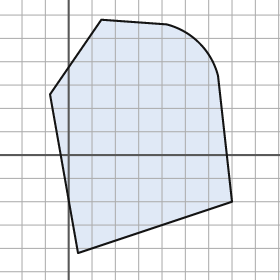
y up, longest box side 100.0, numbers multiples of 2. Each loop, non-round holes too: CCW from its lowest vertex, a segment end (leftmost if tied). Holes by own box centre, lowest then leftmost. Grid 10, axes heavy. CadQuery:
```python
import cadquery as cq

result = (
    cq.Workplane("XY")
    .moveTo(4.0, -42.0)
    .lineTo(70.0, -20.0)
    .lineTo(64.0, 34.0)
    .threePointArc((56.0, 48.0), (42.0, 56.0))
    .lineTo(14.0, 58.0)
    .lineTo(-8.0, 26.0)
    .close()
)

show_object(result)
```